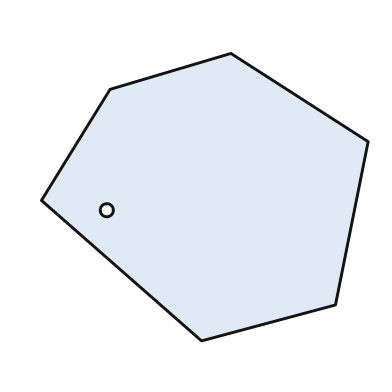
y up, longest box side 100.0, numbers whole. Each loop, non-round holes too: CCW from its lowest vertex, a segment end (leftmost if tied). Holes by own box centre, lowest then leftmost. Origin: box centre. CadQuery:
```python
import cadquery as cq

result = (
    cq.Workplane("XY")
    .moveTo(-1.0, -44.0)
    .lineTo(40.0, -33.0)
    .lineTo(50.0, 17.0)
    .lineTo(8.0, 44.0)
    .lineTo(-29.0, 33.0)
    .lineTo(-50.0, -1.0)
    .close()
    .moveTo(-30.0, -4.0)
    .circle(2.0)
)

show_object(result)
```